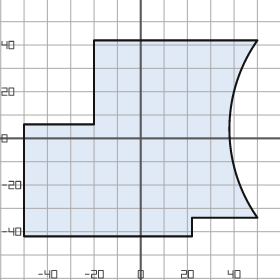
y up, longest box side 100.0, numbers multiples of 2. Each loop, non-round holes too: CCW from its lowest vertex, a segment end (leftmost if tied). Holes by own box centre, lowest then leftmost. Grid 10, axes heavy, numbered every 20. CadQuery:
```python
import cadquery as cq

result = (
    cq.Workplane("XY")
    .moveTo(-50.0, -42.0)
    .lineTo(22.0, -42.0)
    .lineTo(22.0, -34.0)
    .lineTo(50.0, -34.0)
    .threePointArc((38.0, 4.0), (50.0, 42.0))
    .lineTo(-20.0, 42.0)
    .lineTo(-20.0, 6.0)
    .lineTo(-50.0, 6.0)
    .close()
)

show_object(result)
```